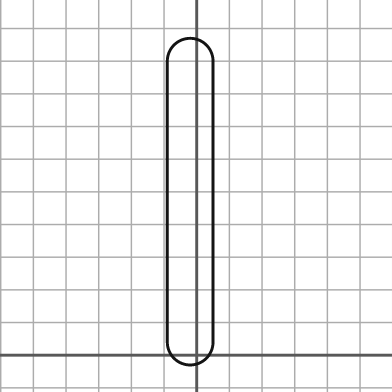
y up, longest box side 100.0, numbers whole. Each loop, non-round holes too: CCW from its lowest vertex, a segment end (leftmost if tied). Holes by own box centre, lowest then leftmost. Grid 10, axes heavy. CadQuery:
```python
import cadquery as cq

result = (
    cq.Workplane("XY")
    .moveTo(-9.0, 4.0)
    .threePointArc((-2.0, -3.0), (5.0, 4.0))
    .lineTo(5.0, 90.0)
    .threePointArc((-2.0, 97.0), (-9.0, 90.0))
    .close()
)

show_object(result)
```